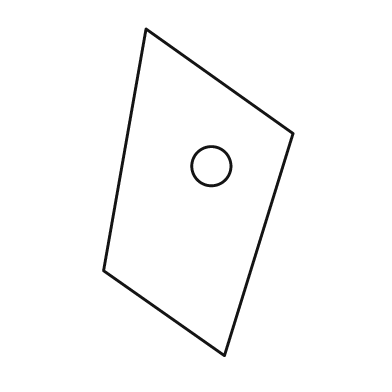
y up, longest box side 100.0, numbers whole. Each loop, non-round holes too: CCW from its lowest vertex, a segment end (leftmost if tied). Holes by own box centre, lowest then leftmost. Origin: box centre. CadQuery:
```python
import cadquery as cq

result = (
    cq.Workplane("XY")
    .moveTo(8.0, -50.0)
    .lineTo(29.0, 18.0)
    .lineTo(-16.0, 50.0)
    .lineTo(-29.0, -24.0)
    .close()
    .moveTo(4.0, 8.0)
    .circle(6.0)
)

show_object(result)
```